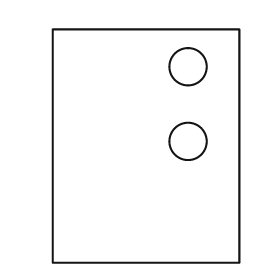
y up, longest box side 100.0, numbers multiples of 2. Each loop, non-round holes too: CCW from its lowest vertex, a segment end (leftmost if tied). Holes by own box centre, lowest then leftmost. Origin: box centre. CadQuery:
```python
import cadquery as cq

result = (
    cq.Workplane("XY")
    .moveTo(-40.0, -50.0)
    .lineTo(40.0, -50.0)
    .lineTo(40.0, 50.0)
    .lineTo(-40.0, 50.0)
    .close()
    .moveTo(18.0, 2.0)
    .circle(8.0)
    .moveTo(18.0, 34.0)
    .circle(8.0)
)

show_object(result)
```